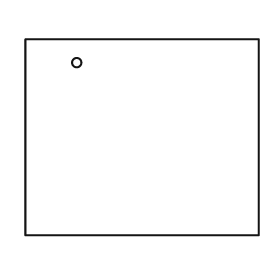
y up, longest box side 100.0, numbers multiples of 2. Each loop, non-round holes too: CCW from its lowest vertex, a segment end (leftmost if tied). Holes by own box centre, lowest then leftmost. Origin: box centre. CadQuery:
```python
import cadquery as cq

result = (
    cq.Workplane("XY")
    .moveTo(-50.0, -42.0)
    .lineTo(50.0, -42.0)
    .lineTo(50.0, 42.0)
    .lineTo(-50.0, 42.0)
    .close()
    .moveTo(-28.0, 32.0)
    .circle(2.0)
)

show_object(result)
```